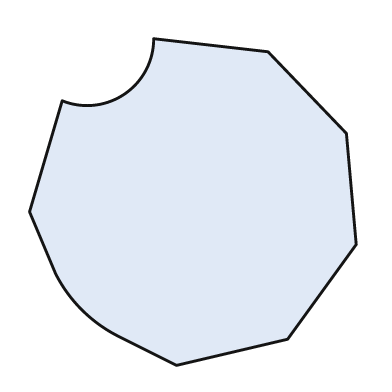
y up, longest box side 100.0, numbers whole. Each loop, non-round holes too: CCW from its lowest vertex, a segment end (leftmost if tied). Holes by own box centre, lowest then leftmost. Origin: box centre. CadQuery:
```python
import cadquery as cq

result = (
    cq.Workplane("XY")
    .moveTo(-5.0, -50.0)
    .lineTo(29.0, -42.0)
    .lineTo(50.0, -13.0)
    .lineTo(47.0, 21.0)
    .lineTo(23.0, 46.0)
    .lineTo(-12.0, 50.0)
    .threePointArc((-21.0, 33.0), (-40.0, 31.0))
    .lineTo(-50.0, -3.0)
    .lineTo(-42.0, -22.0)
    .threePointArc((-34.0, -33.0), (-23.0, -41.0))
    .close()
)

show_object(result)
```